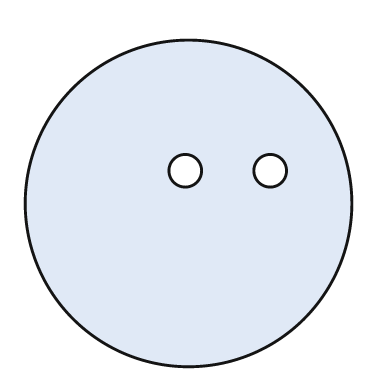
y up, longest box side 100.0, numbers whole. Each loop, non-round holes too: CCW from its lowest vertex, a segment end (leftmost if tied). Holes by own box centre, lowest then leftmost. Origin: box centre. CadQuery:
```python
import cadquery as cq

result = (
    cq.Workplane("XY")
    .moveTo(0.0, 0.0)
    .circle(50.0)
    .moveTo(-1.0, 10.0)
    .circle(5.0)
    .moveTo(25.0, 10.0)
    .circle(5.0)
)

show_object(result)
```